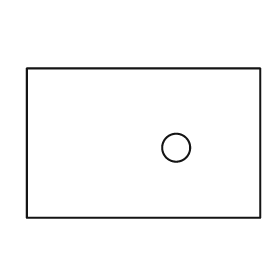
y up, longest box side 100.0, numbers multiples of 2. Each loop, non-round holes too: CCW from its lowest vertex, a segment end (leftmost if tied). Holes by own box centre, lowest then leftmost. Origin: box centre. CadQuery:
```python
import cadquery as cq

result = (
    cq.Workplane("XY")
    .moveTo(-50.0, -32.0)
    .lineTo(50.0, -32.0)
    .lineTo(50.0, 32.0)
    .lineTo(-50.0, 32.0)
    .close()
    .moveTo(14.0, -2.0)
    .circle(6.0)
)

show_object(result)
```